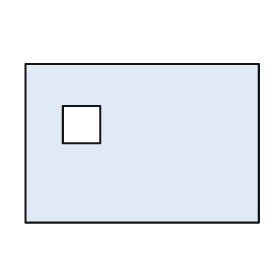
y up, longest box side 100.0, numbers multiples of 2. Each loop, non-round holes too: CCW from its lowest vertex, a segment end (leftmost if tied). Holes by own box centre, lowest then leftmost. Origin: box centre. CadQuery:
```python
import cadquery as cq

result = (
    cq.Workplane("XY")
    .moveTo(-50.0, -34.0)
    .lineTo(50.0, -34.0)
    .lineTo(50.0, 34.0)
    .lineTo(-50.0, 34.0)
    .close()
    .moveTo(-34.0, 0.0)
    .lineTo(-18.0, 0.0)
    .lineTo(-18.0, 16.0)
    .lineTo(-34.0, 16.0)
    .close()
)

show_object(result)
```